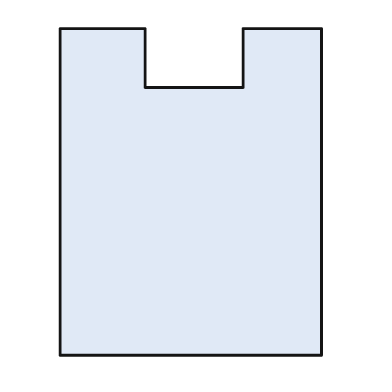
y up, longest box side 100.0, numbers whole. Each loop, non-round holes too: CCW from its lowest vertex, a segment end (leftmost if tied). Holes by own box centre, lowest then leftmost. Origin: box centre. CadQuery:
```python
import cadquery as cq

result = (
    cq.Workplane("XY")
    .moveTo(-40.0, -50.0)
    .lineTo(40.0, -50.0)
    .lineTo(40.0, 50.0)
    .lineTo(16.0, 50.0)
    .lineTo(16.0, 32.0)
    .lineTo(-14.0, 32.0)
    .lineTo(-14.0, 50.0)
    .lineTo(-40.0, 50.0)
    .close()
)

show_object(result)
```